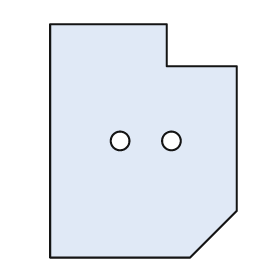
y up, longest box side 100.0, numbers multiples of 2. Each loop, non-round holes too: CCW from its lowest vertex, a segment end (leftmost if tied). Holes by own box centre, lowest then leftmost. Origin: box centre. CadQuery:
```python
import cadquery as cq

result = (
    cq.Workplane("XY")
    .moveTo(-40.0, -50.0)
    .lineTo(20.0, -50.0)
    .lineTo(40.0, -30.0)
    .lineTo(40.0, 32.0)
    .lineTo(10.0, 32.0)
    .lineTo(10.0, 50.0)
    .lineTo(-40.0, 50.0)
    .close()
    .moveTo(-10.0, 0.0)
    .circle(4.0)
    .moveTo(12.0, 0.0)
    .circle(4.0)
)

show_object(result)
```